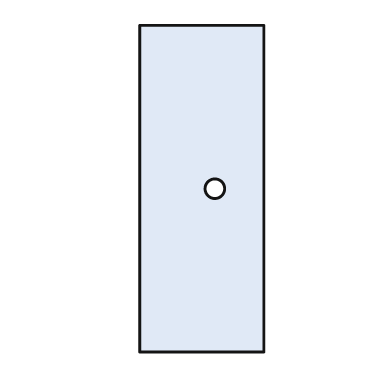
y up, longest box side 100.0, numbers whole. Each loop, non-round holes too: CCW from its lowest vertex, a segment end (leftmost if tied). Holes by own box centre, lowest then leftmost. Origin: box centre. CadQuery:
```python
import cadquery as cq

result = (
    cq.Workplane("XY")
    .moveTo(-19.0, -50.0)
    .lineTo(19.0, -50.0)
    .lineTo(19.0, 50.0)
    .lineTo(-19.0, 50.0)
    .close()
    .moveTo(4.0, 0.0)
    .circle(3.0)
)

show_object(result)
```